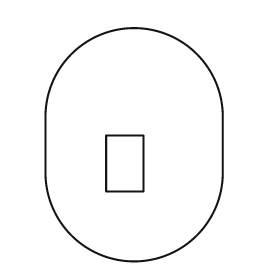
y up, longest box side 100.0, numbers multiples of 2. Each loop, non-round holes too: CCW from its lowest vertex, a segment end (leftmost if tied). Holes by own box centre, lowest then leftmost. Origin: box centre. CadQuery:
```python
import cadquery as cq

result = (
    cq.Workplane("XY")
    .moveTo(-38.0, -12.0)
    .threePointArc((0.0, -50.0), (38.0, -12.0))
    .lineTo(38.0, 12.0)
    .threePointArc((0.0, 50.0), (-38.0, 12.0))
    .close()
    .moveTo(-12.0, -20.0)
    .lineTo(4.0, -20.0)
    .lineTo(4.0, 4.0)
    .lineTo(-12.0, 4.0)
    .close()
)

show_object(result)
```